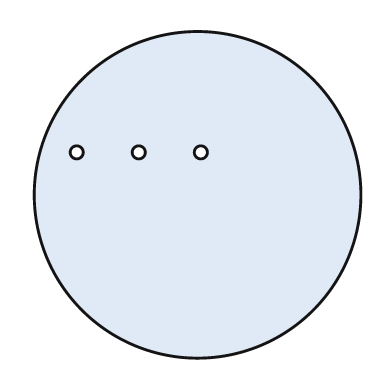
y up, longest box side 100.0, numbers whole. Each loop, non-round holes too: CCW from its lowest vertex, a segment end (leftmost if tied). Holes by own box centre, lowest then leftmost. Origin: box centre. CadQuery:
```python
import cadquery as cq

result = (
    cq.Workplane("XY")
    .moveTo(0.0, 0.0)
    .circle(50.0)
    .moveTo(-37.0, 13.0)
    .circle(2.0)
    .moveTo(-18.0, 13.0)
    .circle(2.0)
    .moveTo(1.0, 13.0)
    .circle(2.0)
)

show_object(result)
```